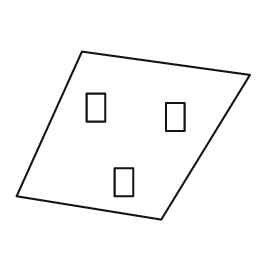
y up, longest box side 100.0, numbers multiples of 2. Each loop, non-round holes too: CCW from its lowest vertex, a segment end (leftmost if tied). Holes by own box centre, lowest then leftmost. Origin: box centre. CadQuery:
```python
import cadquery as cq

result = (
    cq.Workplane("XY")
    .moveTo(12.0, -36.0)
    .lineTo(50.0, 26.0)
    .lineTo(-22.0, 36.0)
    .lineTo(-50.0, -26.0)
    .close()
    .moveTo(-8.0, -26.0)
    .lineTo(0.0, -26.0)
    .lineTo(0.0, -14.0)
    .lineTo(-8.0, -14.0)
    .close()
    .moveTo(14.0, 2.0)
    .lineTo(22.0, 2.0)
    .lineTo(22.0, 14.0)
    .lineTo(14.0, 14.0)
    .close()
    .moveTo(-20.0, 6.0)
    .lineTo(-12.0, 6.0)
    .lineTo(-12.0, 18.0)
    .lineTo(-20.0, 18.0)
    .close()
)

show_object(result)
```